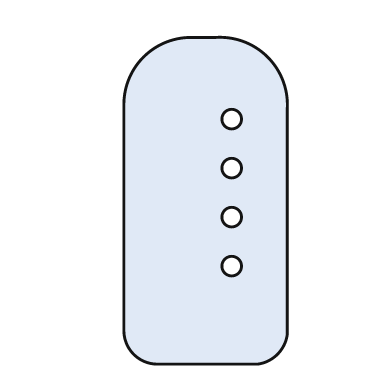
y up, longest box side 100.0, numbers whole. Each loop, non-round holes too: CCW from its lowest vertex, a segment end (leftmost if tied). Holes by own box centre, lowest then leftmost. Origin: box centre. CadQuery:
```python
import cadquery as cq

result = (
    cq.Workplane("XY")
    .moveTo(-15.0, -50.0)
    .lineTo(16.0, -50.0)
    .threePointArc((22.0, -47.0), (25.0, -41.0))
    .lineTo(25.0, 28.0)
    .threePointArc((19.0, 44.0), (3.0, 50.0))
    .lineTo(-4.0, 50.0)
    .threePointArc((-19.0, 44.0), (-25.0, 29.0))
    .lineTo(-25.0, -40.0)
    .threePointArc((-22.0, -47.0), (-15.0, -50.0))
    .close()
    .moveTo(8.0, -20.0)
    .circle(3.0)
    .moveTo(8.0, -5.0)
    .circle(3.0)
    .moveTo(8.0, 10.0)
    .circle(3.0)
    .moveTo(8.0, 25.0)
    .circle(3.0)
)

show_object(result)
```